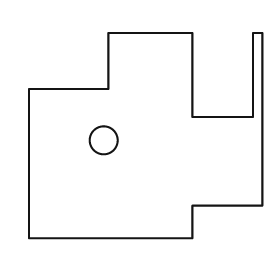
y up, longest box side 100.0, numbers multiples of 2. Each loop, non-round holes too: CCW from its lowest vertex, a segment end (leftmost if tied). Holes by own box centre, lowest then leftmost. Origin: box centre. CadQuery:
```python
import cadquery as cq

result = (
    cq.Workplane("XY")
    .moveTo(-50.0, -44.0)
    .lineTo(20.0, -44.0)
    .lineTo(20.0, -30.0)
    .lineTo(50.0, -30.0)
    .lineTo(50.0, 44.0)
    .lineTo(46.0, 44.0)
    .lineTo(46.0, 8.0)
    .lineTo(20.0, 8.0)
    .lineTo(20.0, 44.0)
    .lineTo(-16.0, 44.0)
    .lineTo(-16.0, 20.0)
    .lineTo(-50.0, 20.0)
    .close()
    .moveTo(-18.0, -2.0)
    .circle(6.0)
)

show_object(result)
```